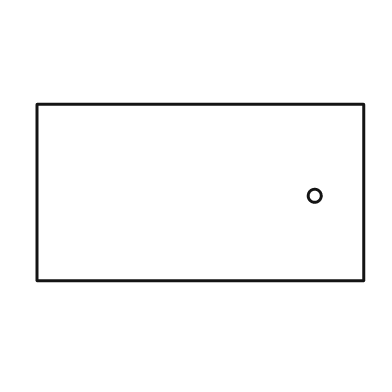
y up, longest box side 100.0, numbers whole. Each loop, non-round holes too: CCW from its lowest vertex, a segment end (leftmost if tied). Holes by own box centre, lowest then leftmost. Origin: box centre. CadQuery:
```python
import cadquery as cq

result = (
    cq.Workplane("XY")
    .moveTo(-50.0, -27.0)
    .lineTo(50.0, -27.0)
    .lineTo(50.0, 27.0)
    .lineTo(-50.0, 27.0)
    .close()
    .moveTo(35.0, -1.0)
    .circle(2.0)
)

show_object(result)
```